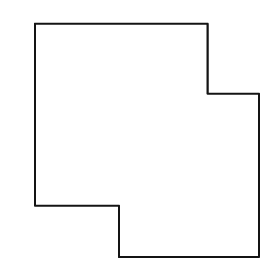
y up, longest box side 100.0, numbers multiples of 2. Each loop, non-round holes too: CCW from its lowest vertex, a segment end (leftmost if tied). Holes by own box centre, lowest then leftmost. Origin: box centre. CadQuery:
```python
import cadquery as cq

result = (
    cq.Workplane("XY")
    .moveTo(-12.0, -50.0)
    .lineTo(48.0, -50.0)
    .lineTo(48.0, 20.0)
    .lineTo(26.0, 20.0)
    .lineTo(26.0, 50.0)
    .lineTo(-48.0, 50.0)
    .lineTo(-48.0, -28.0)
    .lineTo(-12.0, -28.0)
    .close()
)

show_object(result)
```